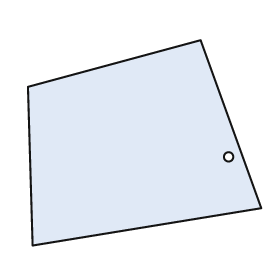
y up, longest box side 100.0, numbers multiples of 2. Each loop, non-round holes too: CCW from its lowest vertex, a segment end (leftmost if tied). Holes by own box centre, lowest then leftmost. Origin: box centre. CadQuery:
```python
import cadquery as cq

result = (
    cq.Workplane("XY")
    .moveTo(-48.0, -44.0)
    .lineTo(50.0, -28.0)
    .lineTo(24.0, 44.0)
    .lineTo(-50.0, 24.0)
    .close()
    .moveTo(36.0, -6.0)
    .circle(2.0)
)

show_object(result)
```